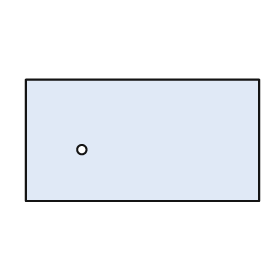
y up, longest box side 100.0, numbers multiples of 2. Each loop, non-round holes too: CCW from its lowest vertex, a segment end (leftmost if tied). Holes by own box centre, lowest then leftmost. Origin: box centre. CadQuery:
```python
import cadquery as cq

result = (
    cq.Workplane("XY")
    .moveTo(-50.0, -26.0)
    .lineTo(50.0, -26.0)
    .lineTo(50.0, 26.0)
    .lineTo(-50.0, 26.0)
    .close()
    .moveTo(-26.0, -4.0)
    .circle(2.0)
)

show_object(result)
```